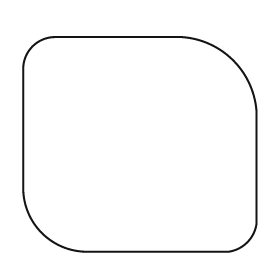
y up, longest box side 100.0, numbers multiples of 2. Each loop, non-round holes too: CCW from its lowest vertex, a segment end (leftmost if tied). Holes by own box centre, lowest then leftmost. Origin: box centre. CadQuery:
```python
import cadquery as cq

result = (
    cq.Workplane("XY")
    .moveTo(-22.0, -46.0)
    .lineTo(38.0, -46.0)
    .threePointArc((46.0, -42.0), (50.0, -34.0))
    .lineTo(50.0, 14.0)
    .threePointArc((40.0, 36.0), (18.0, 46.0))
    .lineTo(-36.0, 46.0)
    .threePointArc((-46.0, 42.0), (-50.0, 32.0))
    .lineTo(-50.0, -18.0)
    .threePointArc((-42.0, -38.0), (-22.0, -46.0))
    .close()
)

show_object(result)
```